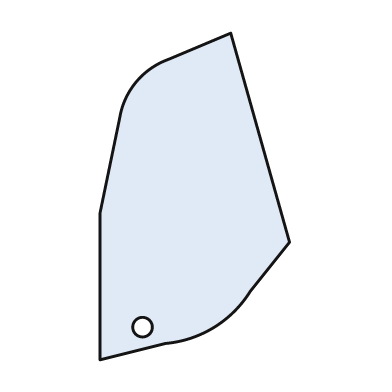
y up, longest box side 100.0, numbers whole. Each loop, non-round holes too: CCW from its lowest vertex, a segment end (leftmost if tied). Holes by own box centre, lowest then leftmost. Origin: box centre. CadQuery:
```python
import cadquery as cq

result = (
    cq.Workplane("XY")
    .moveTo(-29.0, -50.0)
    .lineTo(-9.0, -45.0)
    .threePointArc((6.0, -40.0), (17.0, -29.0))
    .lineTo(29.0, -14.0)
    .lineTo(11.0, 50.0)
    .lineTo(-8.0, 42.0)
    .threePointArc((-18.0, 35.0), (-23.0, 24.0))
    .lineTo(-29.0, -5.0)
    .close()
    .moveTo(-16.0, -40.0)
    .circle(3.0)
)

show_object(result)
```